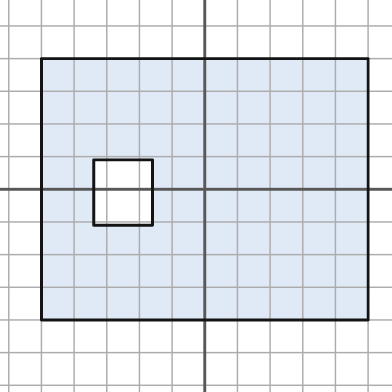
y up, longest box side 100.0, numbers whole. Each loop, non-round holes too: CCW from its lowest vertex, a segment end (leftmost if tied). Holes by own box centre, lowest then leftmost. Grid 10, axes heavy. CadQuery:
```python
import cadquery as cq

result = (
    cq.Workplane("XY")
    .moveTo(-50.0, -40.0)
    .lineTo(50.0, -40.0)
    .lineTo(50.0, 40.0)
    .lineTo(-50.0, 40.0)
    .close()
    .moveTo(-34.0, -11.0)
    .lineTo(-16.0, -11.0)
    .lineTo(-16.0, 9.0)
    .lineTo(-34.0, 9.0)
    .close()
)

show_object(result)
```